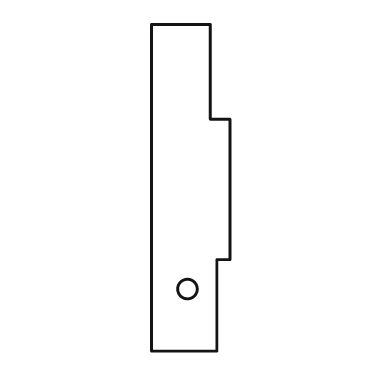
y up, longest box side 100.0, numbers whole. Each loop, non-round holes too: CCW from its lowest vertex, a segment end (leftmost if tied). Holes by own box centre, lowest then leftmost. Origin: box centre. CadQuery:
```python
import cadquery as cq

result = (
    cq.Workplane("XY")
    .moveTo(-12.0, -50.0)
    .lineTo(8.0, -50.0)
    .lineTo(8.0, -22.0)
    .lineTo(12.0, -22.0)
    .lineTo(12.0, 21.0)
    .lineTo(6.0, 21.0)
    .lineTo(6.0, 50.0)
    .lineTo(-12.0, 50.0)
    .close()
    .moveTo(-1.0, -31.0)
    .circle(3.0)
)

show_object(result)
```